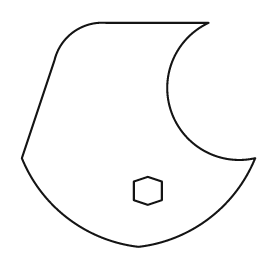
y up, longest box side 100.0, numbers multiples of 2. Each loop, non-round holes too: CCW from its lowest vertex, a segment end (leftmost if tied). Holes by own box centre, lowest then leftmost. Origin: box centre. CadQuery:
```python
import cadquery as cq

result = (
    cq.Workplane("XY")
    .moveTo(0.0, -48.0)
    .threePointArc((30.0, -36.0), (50.0, -10.0))
    .threePointArc((14.0, 10.0), (30.0, 48.0))
    .lineTo(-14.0, 48.0)
    .threePointArc((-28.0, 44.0), (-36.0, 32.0))
    .lineTo(-50.0, -10.0)
    .threePointArc((-30.0, -36.0), (0.0, -48.0))
    .close()
    .moveTo(4.0, -30.0)
    .lineTo(10.0, -28.0)
    .lineTo(10.0, -20.0)
    .lineTo(4.0, -18.0)
    .lineTo(-2.0, -20.0)
    .lineTo(-2.0, -28.0)
    .close()
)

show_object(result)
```